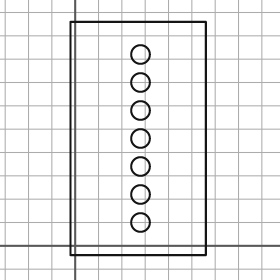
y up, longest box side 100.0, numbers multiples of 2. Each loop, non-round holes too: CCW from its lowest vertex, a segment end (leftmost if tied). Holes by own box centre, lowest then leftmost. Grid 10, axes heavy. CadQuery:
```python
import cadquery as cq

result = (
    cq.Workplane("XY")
    .moveTo(-2.0, -4.0)
    .lineTo(56.0, -4.0)
    .lineTo(56.0, 96.0)
    .lineTo(-2.0, 96.0)
    .close()
    .moveTo(28.0, 10.0)
    .circle(4.0)
    .moveTo(28.0, 22.0)
    .circle(4.0)
    .moveTo(28.0, 34.0)
    .circle(4.0)
    .moveTo(28.0, 46.0)
    .circle(4.0)
    .moveTo(28.0, 58.0)
    .circle(4.0)
    .moveTo(28.0, 70.0)
    .circle(4.0)
    .moveTo(28.0, 82.0)
    .circle(4.0)
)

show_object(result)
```